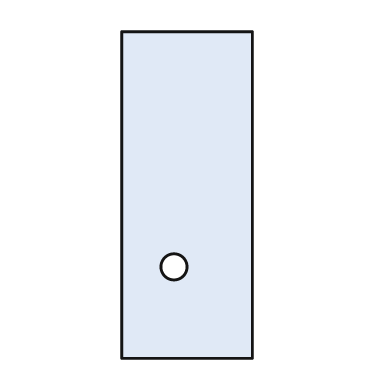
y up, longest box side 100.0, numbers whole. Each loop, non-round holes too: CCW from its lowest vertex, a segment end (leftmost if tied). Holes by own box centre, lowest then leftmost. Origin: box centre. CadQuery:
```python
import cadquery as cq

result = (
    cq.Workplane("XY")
    .moveTo(-20.0, -50.0)
    .lineTo(20.0, -50.0)
    .lineTo(20.0, 50.0)
    .lineTo(-20.0, 50.0)
    .close()
    .moveTo(-4.0, -22.0)
    .circle(4.0)
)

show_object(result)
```